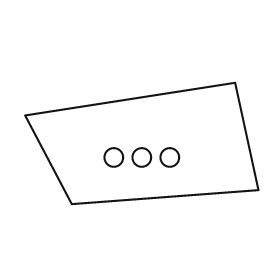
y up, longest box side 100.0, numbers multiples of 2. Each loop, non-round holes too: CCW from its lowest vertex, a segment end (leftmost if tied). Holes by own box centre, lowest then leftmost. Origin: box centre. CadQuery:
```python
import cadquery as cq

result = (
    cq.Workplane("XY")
    .moveTo(-30.0, -26.0)
    .lineTo(50.0, -20.0)
    .lineTo(40.0, 26.0)
    .lineTo(-50.0, 12.0)
    .close()
    .moveTo(-12.0, -6.0)
    .circle(4.0)
    .moveTo(0.0, -6.0)
    .circle(4.0)
    .moveTo(12.0, -6.0)
    .circle(4.0)
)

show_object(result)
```